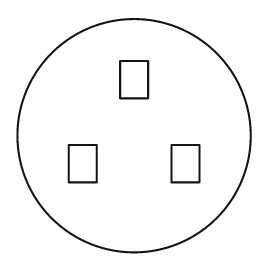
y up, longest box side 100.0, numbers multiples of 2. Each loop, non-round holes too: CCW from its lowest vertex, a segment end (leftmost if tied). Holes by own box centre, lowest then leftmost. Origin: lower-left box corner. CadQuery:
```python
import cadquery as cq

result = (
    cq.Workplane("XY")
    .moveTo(50.0, 50.0)
    .circle(50.0)
    .moveTo(22.0, 30.0)
    .lineTo(34.0, 30.0)
    .lineTo(34.0, 46.0)
    .lineTo(22.0, 46.0)
    .close()
    .moveTo(66.0, 30.0)
    .lineTo(78.0, 30.0)
    .lineTo(78.0, 46.0)
    .lineTo(66.0, 46.0)
    .close()
    .moveTo(44.0, 66.0)
    .lineTo(56.0, 66.0)
    .lineTo(56.0, 82.0)
    .lineTo(44.0, 82.0)
    .close()
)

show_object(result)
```